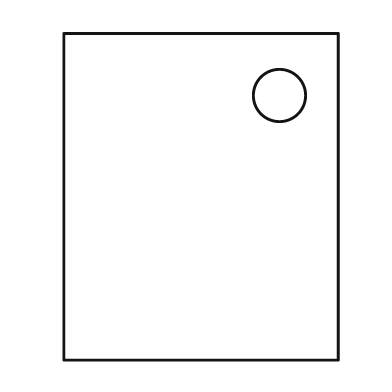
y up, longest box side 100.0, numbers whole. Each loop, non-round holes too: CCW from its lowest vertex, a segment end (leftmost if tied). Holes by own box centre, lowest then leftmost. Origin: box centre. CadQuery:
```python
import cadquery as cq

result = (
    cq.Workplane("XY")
    .moveTo(-42.0, -50.0)
    .lineTo(42.0, -50.0)
    .lineTo(42.0, 50.0)
    .lineTo(-42.0, 50.0)
    .close()
    .moveTo(24.0, 31.0)
    .circle(8.0)
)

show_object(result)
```